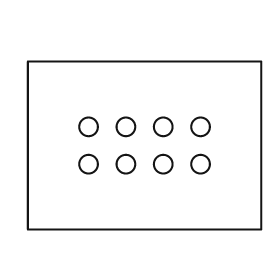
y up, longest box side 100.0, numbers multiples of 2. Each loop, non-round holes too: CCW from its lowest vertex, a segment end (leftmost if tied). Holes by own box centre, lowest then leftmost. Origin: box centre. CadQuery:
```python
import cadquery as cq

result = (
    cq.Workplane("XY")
    .moveTo(-50.0, -36.0)
    .lineTo(50.0, -36.0)
    .lineTo(50.0, 36.0)
    .lineTo(-50.0, 36.0)
    .close()
    .moveTo(-24.0, -8.0)
    .circle(4.0)
    .moveTo(-8.0, -8.0)
    .circle(4.0)
    .moveTo(8.0, -8.0)
    .circle(4.0)
    .moveTo(24.0, -8.0)
    .circle(4.0)
    .moveTo(-24.0, 8.0)
    .circle(4.0)
    .moveTo(-8.0, 8.0)
    .circle(4.0)
    .moveTo(8.0, 8.0)
    .circle(4.0)
    .moveTo(24.0, 8.0)
    .circle(4.0)
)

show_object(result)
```